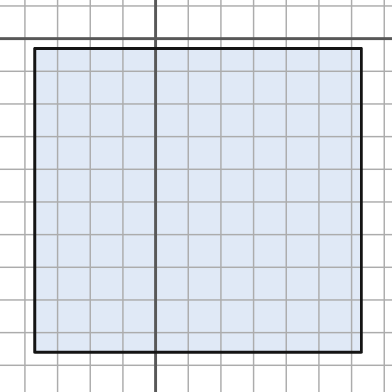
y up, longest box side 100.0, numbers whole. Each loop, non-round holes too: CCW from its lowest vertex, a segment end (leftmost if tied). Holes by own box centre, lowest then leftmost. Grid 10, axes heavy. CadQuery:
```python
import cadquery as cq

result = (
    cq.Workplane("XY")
    .moveTo(-37.0, -96.0)
    .lineTo(63.0, -96.0)
    .lineTo(63.0, -3.0)
    .lineTo(-37.0, -3.0)
    .close()
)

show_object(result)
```